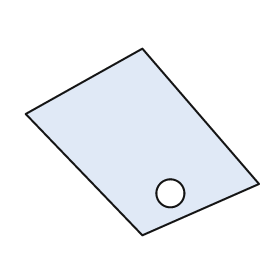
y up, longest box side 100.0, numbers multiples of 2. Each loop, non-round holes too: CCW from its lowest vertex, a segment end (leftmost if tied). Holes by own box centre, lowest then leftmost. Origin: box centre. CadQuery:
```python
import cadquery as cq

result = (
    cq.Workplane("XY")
    .moveTo(0.0, -40.0)
    .lineTo(50.0, -18.0)
    .lineTo(0.0, 40.0)
    .lineTo(-50.0, 12.0)
    .close()
    .moveTo(12.0, -22.0)
    .circle(6.0)
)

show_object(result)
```